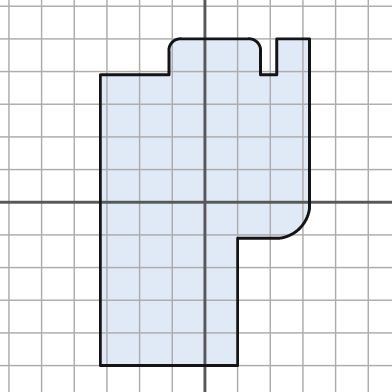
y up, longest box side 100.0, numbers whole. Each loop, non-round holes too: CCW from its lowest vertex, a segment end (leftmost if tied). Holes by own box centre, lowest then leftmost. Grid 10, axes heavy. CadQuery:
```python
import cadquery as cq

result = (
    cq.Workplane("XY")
    .moveTo(-32.0, -50.0)
    .lineTo(10.0, -50.0)
    .lineTo(10.0, -11.0)
    .lineTo(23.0, -11.0)
    .threePointArc((29.0, -8.0), (32.0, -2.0))
    .lineTo(32.0, 50.0)
    .lineTo(22.0, 50.0)
    .lineTo(22.0, 39.0)
    .lineTo(17.0, 39.0)
    .lineTo(17.0, 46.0)
    .threePointArc((16.0, 49.0), (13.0, 50.0))
    .lineTo(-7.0, 50.0)
    .threePointArc((-10.0, 49.0), (-11.0, 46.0))
    .lineTo(-11.0, 39.0)
    .lineTo(-32.0, 39.0)
    .close()
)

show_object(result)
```